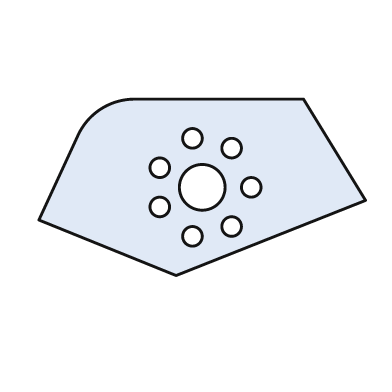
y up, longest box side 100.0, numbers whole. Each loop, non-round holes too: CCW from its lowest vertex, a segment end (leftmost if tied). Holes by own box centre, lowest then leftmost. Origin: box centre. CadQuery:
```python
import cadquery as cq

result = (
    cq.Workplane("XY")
    .moveTo(-8.0, -27.0)
    .lineTo(50.0, -4.0)
    .lineTo(31.0, 27.0)
    .lineTo(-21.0, 27.0)
    .threePointArc((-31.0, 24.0), (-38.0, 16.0))
    .lineTo(-50.0, -10.0)
    .close()
    .moveTo(-3.0, -15.0)
    .circle(3.0)
    .moveTo(9.0, -12.0)
    .circle(3.0)
    .moveTo(-13.0, -6.0)
    .circle(3.0)
    .moveTo(0.0, 0.0)
    .circle(7.0)
    .moveTo(15.0, 0.0)
    .circle(3.0)
    .moveTo(-13.0, 6.0)
    .circle(3.0)
    .moveTo(9.0, 12.0)
    .circle(3.0)
    .moveTo(-3.0, 15.0)
    .circle(3.0)
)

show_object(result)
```